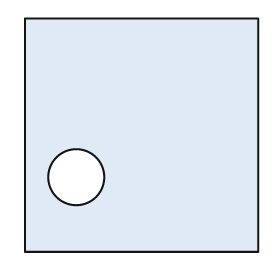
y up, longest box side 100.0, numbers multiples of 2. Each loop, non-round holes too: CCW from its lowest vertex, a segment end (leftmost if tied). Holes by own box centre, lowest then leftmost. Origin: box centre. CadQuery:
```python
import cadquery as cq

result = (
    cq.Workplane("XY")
    .moveTo(-50.0, -50.0)
    .lineTo(50.0, -50.0)
    .lineTo(50.0, 50.0)
    .lineTo(-50.0, 50.0)
    .close()
    .moveTo(-28.0, -18.0)
    .circle(12.0)
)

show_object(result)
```